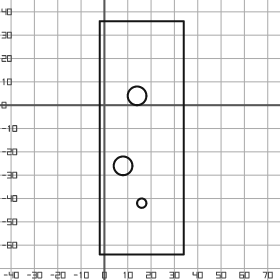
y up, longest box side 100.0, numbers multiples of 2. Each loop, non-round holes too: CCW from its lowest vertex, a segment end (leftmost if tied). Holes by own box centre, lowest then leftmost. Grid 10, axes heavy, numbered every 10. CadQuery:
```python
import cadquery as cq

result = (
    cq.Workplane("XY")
    .moveTo(-2.0, -64.0)
    .lineTo(34.0, -64.0)
    .lineTo(34.0, 36.0)
    .lineTo(-2.0, 36.0)
    .close()
    .moveTo(16.0, -42.0)
    .circle(2.0)
    .moveTo(8.0, -26.0)
    .circle(4.0)
    .moveTo(14.0, 4.0)
    .circle(4.0)
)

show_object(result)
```